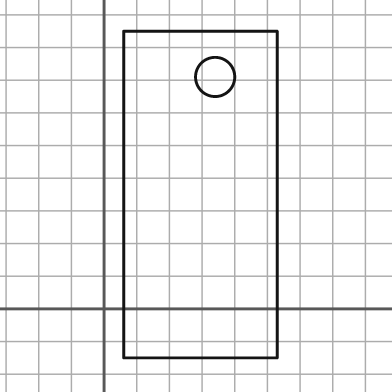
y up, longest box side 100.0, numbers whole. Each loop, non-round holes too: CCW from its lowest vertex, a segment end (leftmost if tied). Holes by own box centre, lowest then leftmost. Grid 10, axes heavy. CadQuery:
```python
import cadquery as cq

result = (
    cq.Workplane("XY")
    .moveTo(6.0, -15.0)
    .lineTo(53.0, -15.0)
    .lineTo(53.0, 85.0)
    .lineTo(6.0, 85.0)
    .close()
    .moveTo(34.0, 71.0)
    .circle(6.0)
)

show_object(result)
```